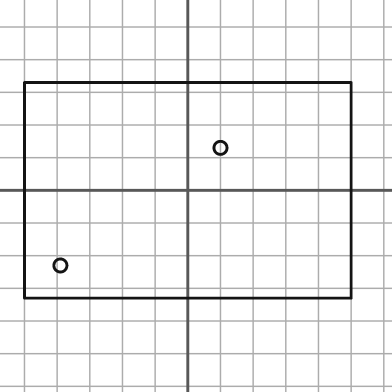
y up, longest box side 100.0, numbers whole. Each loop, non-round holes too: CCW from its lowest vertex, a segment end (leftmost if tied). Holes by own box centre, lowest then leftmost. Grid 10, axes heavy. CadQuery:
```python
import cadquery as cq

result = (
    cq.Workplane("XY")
    .moveTo(-50.0, -33.0)
    .lineTo(50.0, -33.0)
    .lineTo(50.0, 33.0)
    .lineTo(-50.0, 33.0)
    .close()
    .moveTo(-39.0, -23.0)
    .circle(2.0)
    .moveTo(10.0, 13.0)
    .circle(2.0)
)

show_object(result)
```